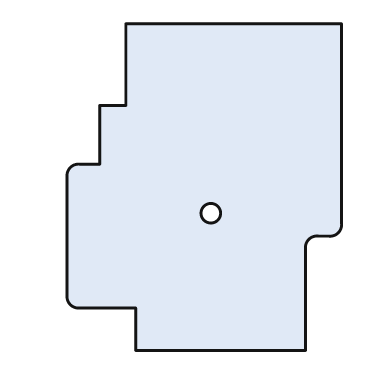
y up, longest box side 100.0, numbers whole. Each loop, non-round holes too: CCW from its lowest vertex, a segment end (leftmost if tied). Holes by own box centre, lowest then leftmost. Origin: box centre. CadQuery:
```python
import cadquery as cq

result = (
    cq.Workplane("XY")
    .moveTo(-21.0, -50.0)
    .lineTo(31.0, -50.0)
    .lineTo(31.0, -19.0)
    .threePointArc((32.0, -16.0), (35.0, -15.0))
    .lineTo(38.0, -15.0)
    .threePointArc((41.0, -14.0), (42.0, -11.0))
    .lineTo(42.0, 50.0)
    .lineTo(-24.0, 50.0)
    .lineTo(-24.0, 25.0)
    .lineTo(-32.0, 25.0)
    .lineTo(-32.0, 7.0)
    .lineTo(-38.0, 7.0)
    .threePointArc((-41.0, 6.0), (-42.0, 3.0))
    .lineTo(-42.0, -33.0)
    .threePointArc((-41.0, -36.0), (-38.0, -37.0))
    .lineTo(-21.0, -37.0)
    .close()
    .moveTo(2.0, -8.0)
    .circle(3.0)
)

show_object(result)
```